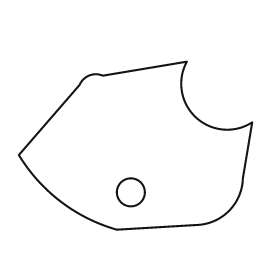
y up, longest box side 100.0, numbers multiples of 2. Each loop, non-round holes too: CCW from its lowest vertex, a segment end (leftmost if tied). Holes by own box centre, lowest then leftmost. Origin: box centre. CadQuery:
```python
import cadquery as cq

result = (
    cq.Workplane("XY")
    .moveTo(-8.0, -36.0)
    .lineTo(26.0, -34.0)
    .threePointArc((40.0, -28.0), (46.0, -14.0))
    .lineTo(50.0, 10.0)
    .threePointArc((26.0, 12.0), (22.0, 36.0))
    .lineTo(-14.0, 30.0)
    .threePointArc((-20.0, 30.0), (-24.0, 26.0))
    .lineTo(-50.0, -4.0)
    .threePointArc((-32.0, -24.0), (-8.0, -36.0))
    .close()
    .moveTo(-2.0, -20.0)
    .circle(6.0)
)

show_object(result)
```